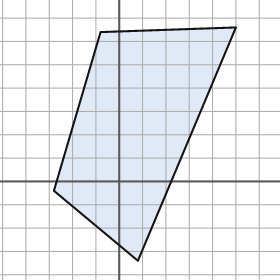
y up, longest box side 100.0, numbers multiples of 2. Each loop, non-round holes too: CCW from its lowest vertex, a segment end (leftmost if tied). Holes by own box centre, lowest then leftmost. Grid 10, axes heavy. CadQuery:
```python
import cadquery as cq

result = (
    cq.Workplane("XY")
    .moveTo(8.0, -34.0)
    .lineTo(50.0, 66.0)
    .lineTo(-8.0, 64.0)
    .lineTo(-28.0, -4.0)
    .close()
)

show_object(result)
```